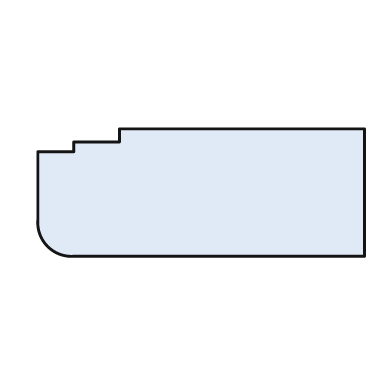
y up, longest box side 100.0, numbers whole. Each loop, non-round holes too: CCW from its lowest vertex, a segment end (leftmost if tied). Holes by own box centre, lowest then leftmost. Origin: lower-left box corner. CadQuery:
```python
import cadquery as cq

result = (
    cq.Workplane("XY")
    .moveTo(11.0, 0.0)
    .lineTo(100.0, 0.0)
    .lineTo(100.0, 39.0)
    .lineTo(25.0, 39.0)
    .lineTo(25.0, 35.0)
    .lineTo(11.0, 35.0)
    .lineTo(11.0, 32.0)
    .lineTo(0.0, 32.0)
    .lineTo(0.0, 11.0)
    .threePointArc((3.0, 3.0), (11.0, 0.0))
    .close()
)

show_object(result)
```